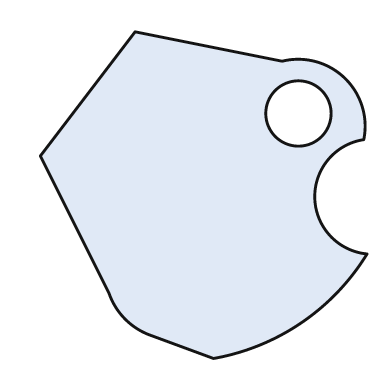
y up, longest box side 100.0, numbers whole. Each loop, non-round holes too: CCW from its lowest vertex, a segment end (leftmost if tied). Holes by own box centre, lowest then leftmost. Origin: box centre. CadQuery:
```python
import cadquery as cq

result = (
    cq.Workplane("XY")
    .moveTo(3.0, -50.0)
    .threePointArc((30.0, -39.0), (50.0, -18.0))
    .threePointArc((34.0, -1.0), (49.0, 17.0))
    .threePointArc((43.0, 36.0), (24.0, 41.0))
    .lineTo(-21.0, 50.0)
    .lineTo(-50.0, 12.0)
    .lineTo(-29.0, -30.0)
    .threePointArc((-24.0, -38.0), (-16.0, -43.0))
    .close()
    .moveTo(29.0, 25.0)
    .circle(10.0)
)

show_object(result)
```